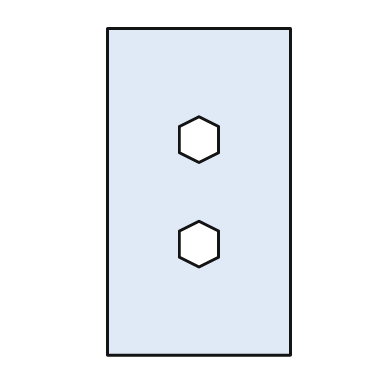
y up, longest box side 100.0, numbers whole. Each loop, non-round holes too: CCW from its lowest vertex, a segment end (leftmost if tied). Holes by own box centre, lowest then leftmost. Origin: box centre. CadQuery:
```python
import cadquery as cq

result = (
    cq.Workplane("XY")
    .moveTo(-28.0, -50.0)
    .lineTo(28.0, -50.0)
    .lineTo(28.0, 50.0)
    .lineTo(-28.0, 50.0)
    .close()
    .moveTo(0.0, -23.0)
    .lineTo(6.0, -20.0)
    .lineTo(6.0, -12.0)
    .lineTo(0.0, -9.0)
    .lineTo(-6.0, -12.0)
    .lineTo(-6.0, -20.0)
    .close()
    .moveTo(0.0, 9.0)
    .lineTo(6.0, 12.0)
    .lineTo(6.0, 20.0)
    .lineTo(0.0, 23.0)
    .lineTo(-6.0, 20.0)
    .lineTo(-6.0, 12.0)
    .close()
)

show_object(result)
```